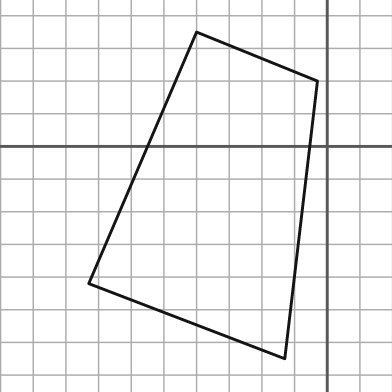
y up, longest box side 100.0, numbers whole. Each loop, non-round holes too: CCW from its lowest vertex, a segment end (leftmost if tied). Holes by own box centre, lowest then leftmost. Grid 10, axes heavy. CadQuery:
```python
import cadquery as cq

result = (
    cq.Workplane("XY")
    .moveTo(-13.0, -65.0)
    .lineTo(-3.0, 20.0)
    .lineTo(-40.0, 35.0)
    .lineTo(-73.0, -42.0)
    .close()
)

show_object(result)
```